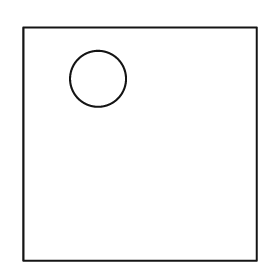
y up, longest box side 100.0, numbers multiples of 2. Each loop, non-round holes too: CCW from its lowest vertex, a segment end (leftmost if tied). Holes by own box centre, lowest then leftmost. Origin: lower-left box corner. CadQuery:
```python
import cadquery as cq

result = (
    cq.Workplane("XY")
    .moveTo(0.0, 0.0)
    .lineTo(100.0, 0.0)
    .lineTo(100.0, 100.0)
    .lineTo(0.0, 100.0)
    .close()
    .moveTo(32.0, 78.0)
    .circle(12.0)
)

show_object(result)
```